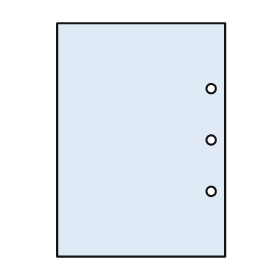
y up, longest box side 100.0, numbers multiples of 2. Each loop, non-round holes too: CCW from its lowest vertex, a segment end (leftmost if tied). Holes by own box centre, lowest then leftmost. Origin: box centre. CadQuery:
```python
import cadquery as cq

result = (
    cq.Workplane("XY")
    .moveTo(-36.0, -50.0)
    .lineTo(36.0, -50.0)
    .lineTo(36.0, 50.0)
    .lineTo(-36.0, 50.0)
    .close()
    .moveTo(30.0, -22.0)
    .circle(2.0)
    .moveTo(30.0, 0.0)
    .circle(2.0)
    .moveTo(30.0, 22.0)
    .circle(2.0)
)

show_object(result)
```